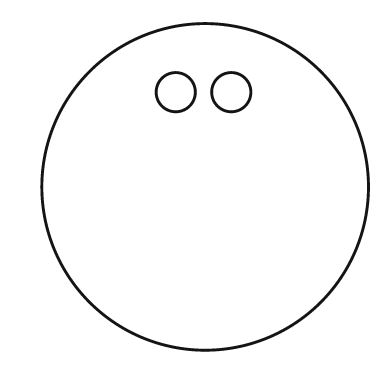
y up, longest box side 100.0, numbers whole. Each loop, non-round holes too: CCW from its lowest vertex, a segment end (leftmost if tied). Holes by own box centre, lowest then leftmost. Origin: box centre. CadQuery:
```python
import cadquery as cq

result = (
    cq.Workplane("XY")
    .moveTo(0.0, 0.0)
    .circle(50.0)
    .moveTo(-9.0, 29.0)
    .circle(6.0)
    .moveTo(8.0, 29.0)
    .circle(6.0)
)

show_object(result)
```